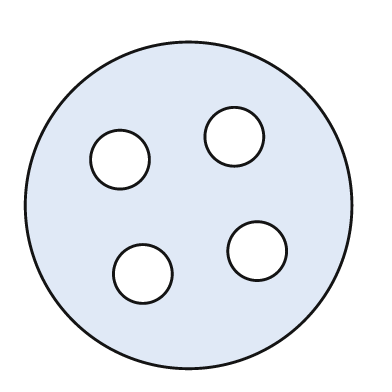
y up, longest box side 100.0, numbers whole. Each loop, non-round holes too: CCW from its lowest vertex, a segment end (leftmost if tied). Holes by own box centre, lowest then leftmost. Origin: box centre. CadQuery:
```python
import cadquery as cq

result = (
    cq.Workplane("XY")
    .moveTo(0.0, 0.0)
    .circle(50.0)
    .moveTo(-14.0, -21.0)
    .circle(9.0)
    .moveTo(21.0, -14.0)
    .circle(9.0)
    .moveTo(-21.0, 14.0)
    .circle(9.0)
    .moveTo(14.0, 21.0)
    .circle(9.0)
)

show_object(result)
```